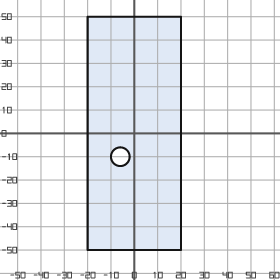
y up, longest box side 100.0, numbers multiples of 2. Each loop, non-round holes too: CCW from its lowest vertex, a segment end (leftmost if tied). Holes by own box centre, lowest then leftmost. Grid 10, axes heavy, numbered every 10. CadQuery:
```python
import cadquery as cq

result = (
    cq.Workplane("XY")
    .moveTo(-20.0, -50.0)
    .lineTo(20.0, -50.0)
    .lineTo(20.0, 50.0)
    .lineTo(-20.0, 50.0)
    .close()
    .moveTo(-6.0, -10.0)
    .circle(4.0)
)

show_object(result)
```